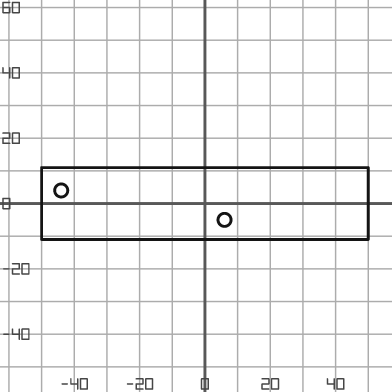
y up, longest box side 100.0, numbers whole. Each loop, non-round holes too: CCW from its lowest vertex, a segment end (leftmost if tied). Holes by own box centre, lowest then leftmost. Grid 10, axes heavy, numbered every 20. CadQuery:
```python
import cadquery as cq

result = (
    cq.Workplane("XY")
    .moveTo(-50.0, -11.0)
    .lineTo(50.0, -11.0)
    .lineTo(50.0, 11.0)
    .lineTo(-50.0, 11.0)
    .close()
    .moveTo(6.0, -5.0)
    .circle(2.0)
    .moveTo(-44.0, 4.0)
    .circle(2.0)
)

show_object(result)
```